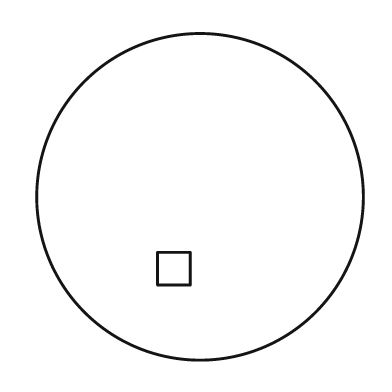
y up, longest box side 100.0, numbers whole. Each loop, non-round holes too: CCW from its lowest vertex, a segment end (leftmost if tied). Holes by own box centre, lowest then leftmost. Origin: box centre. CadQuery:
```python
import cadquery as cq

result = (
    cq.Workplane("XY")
    .moveTo(0.0, 0.0)
    .circle(50.0)
    .moveTo(-13.0, -27.0)
    .lineTo(-3.0, -27.0)
    .lineTo(-3.0, -17.0)
    .lineTo(-13.0, -17.0)
    .close()
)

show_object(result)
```